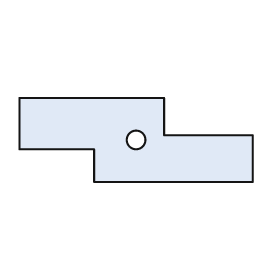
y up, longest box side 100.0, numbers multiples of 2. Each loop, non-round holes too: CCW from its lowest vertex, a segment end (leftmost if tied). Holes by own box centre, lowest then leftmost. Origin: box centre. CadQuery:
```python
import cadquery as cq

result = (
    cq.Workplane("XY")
    .moveTo(-18.0, -18.0)
    .lineTo(50.0, -18.0)
    .lineTo(50.0, 2.0)
    .lineTo(12.0, 2.0)
    .lineTo(12.0, 18.0)
    .lineTo(-50.0, 18.0)
    .lineTo(-50.0, -4.0)
    .lineTo(-18.0, -4.0)
    .close()
    .moveTo(0.0, 0.0)
    .circle(4.0)
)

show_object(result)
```